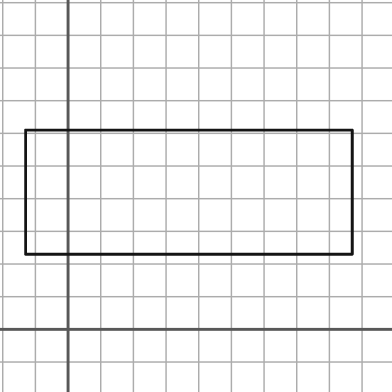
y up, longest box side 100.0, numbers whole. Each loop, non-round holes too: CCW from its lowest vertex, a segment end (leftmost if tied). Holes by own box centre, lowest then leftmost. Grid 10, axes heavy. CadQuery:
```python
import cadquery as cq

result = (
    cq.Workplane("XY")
    .moveTo(-13.0, 23.0)
    .lineTo(87.0, 23.0)
    .lineTo(87.0, 61.0)
    .lineTo(-13.0, 61.0)
    .close()
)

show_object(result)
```